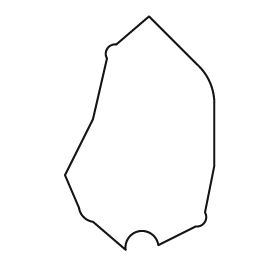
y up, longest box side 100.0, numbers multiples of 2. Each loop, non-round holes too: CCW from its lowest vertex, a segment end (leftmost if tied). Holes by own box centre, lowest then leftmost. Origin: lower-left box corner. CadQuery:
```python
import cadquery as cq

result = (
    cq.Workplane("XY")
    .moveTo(26.0, 0.0)
    .threePointArc((32.0, 8.0), (40.0, 2.0))
    .lineTo(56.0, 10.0)
    .threePointArc((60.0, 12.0), (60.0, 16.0))
    .lineTo(64.0, 36.0)
    .lineTo(64.0, 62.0)
    .threePointArc((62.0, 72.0), (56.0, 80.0))
    .lineTo(36.0, 100.0)
    .lineTo(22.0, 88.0)
    .threePointArc((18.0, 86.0), (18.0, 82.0))
    .lineTo(12.0, 56.0)
    .lineTo(0.0, 32.0)
    .lineTo(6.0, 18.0)
    .threePointArc((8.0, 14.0), (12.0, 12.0))
    .close()
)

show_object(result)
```